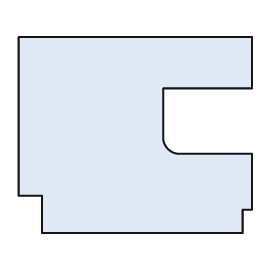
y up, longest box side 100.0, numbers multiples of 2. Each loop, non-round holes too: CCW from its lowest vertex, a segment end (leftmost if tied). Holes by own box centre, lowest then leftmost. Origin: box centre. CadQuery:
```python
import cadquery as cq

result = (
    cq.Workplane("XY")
    .moveTo(-40.0, -42.0)
    .lineTo(46.0, -42.0)
    .lineTo(46.0, -32.0)
    .lineTo(50.0, -32.0)
    .lineTo(50.0, -8.0)
    .lineTo(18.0, -8.0)
    .threePointArc((14.0, -6.0), (12.0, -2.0))
    .lineTo(12.0, 20.0)
    .lineTo(50.0, 20.0)
    .lineTo(50.0, 42.0)
    .lineTo(-50.0, 42.0)
    .lineTo(-50.0, -26.0)
    .lineTo(-40.0, -26.0)
    .close()
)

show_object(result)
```